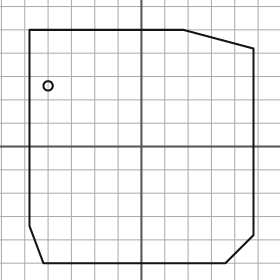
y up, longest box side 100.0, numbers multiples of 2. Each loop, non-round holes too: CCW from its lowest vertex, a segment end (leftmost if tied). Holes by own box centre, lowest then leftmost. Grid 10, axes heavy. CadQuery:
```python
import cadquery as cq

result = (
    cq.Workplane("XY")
    .moveTo(-42.0, -50.0)
    .lineTo(36.0, -50.0)
    .lineTo(48.0, -38.0)
    .lineTo(48.0, 42.0)
    .lineTo(18.0, 50.0)
    .lineTo(-48.0, 50.0)
    .lineTo(-48.0, -34.0)
    .close()
    .moveTo(-40.0, 26.0)
    .circle(2.0)
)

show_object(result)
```